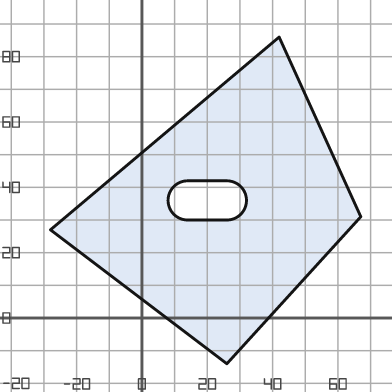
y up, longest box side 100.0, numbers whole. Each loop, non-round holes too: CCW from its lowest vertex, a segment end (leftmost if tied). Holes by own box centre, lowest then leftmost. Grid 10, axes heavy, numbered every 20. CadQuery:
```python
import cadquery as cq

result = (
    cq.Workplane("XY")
    .moveTo(26.0, -14.0)
    .lineTo(67.0, 31.0)
    .lineTo(42.0, 86.0)
    .lineTo(-28.0, 27.0)
    .close()
    .moveTo(14.0, 30.0)
    .lineTo(26.0, 30.0)
    .threePointArc((32.0, 36.0), (26.0, 42.0))
    .lineTo(14.0, 42.0)
    .threePointArc((8.0, 36.0), (14.0, 30.0))
    .close()
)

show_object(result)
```